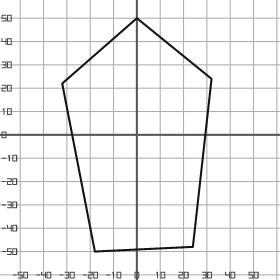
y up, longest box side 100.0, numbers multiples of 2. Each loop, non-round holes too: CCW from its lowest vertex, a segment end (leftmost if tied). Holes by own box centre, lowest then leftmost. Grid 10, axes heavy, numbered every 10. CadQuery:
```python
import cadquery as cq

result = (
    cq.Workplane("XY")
    .moveTo(-18.0, -50.0)
    .lineTo(24.0, -48.0)
    .lineTo(32.0, 24.0)
    .lineTo(0.0, 50.0)
    .lineTo(-32.0, 22.0)
    .close()
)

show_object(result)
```